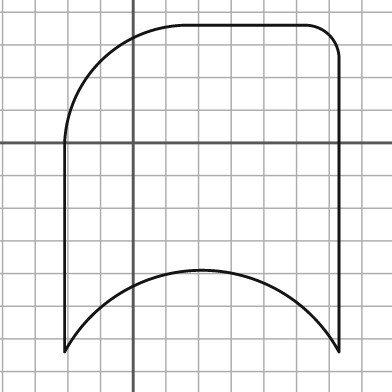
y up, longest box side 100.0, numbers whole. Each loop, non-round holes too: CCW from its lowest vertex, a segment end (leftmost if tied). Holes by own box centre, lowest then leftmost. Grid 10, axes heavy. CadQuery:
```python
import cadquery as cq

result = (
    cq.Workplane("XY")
    .moveTo(-21.0, -64.0)
    .threePointArc((21.0, -39.0), (63.0, -64.0))
    .lineTo(63.0, 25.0)
    .threePointArc((60.0, 33.0), (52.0, 36.0))
    .lineTo(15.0, 36.0)
    .threePointArc((-10.0, 25.0), (-21.0, 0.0))
    .close()
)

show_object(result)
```